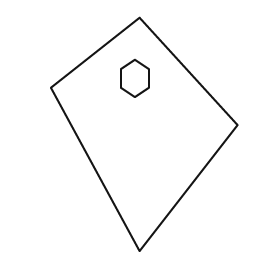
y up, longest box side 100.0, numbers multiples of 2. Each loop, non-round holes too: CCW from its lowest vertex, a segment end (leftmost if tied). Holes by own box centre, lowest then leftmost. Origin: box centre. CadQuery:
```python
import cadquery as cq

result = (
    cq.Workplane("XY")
    .moveTo(-2.0, -50.0)
    .lineTo(40.0, 4.0)
    .lineTo(-2.0, 50.0)
    .lineTo(-40.0, 20.0)
    .close()
    .moveTo(-4.0, 16.0)
    .lineTo(2.0, 20.0)
    .lineTo(2.0, 28.0)
    .lineTo(-4.0, 32.0)
    .lineTo(-10.0, 28.0)
    .lineTo(-10.0, 20.0)
    .close()
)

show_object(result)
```